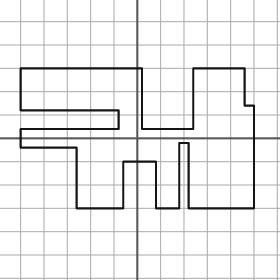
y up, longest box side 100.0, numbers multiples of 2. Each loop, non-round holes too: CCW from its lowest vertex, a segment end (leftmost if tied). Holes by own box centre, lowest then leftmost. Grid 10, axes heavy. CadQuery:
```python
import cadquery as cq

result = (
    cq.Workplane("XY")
    .moveTo(-26.0, -30.0)
    .lineTo(-6.0, -30.0)
    .lineTo(-6.0, -10.0)
    .lineTo(8.0, -10.0)
    .lineTo(8.0, -30.0)
    .lineTo(18.0, -30.0)
    .lineTo(18.0, -2.0)
    .lineTo(22.0, -2.0)
    .lineTo(22.0, -30.0)
    .lineTo(50.0, -30.0)
    .lineTo(50.0, 14.0)
    .lineTo(46.0, 14.0)
    .lineTo(46.0, 30.0)
    .lineTo(24.0, 30.0)
    .lineTo(24.0, 4.0)
    .lineTo(2.0, 4.0)
    .lineTo(2.0, 30.0)
    .lineTo(-50.0, 30.0)
    .lineTo(-50.0, 12.0)
    .lineTo(-8.0, 12.0)
    .lineTo(-8.0, 4.0)
    .lineTo(-50.0, 4.0)
    .lineTo(-50.0, -4.0)
    .lineTo(-26.0, -4.0)
    .close()
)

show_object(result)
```